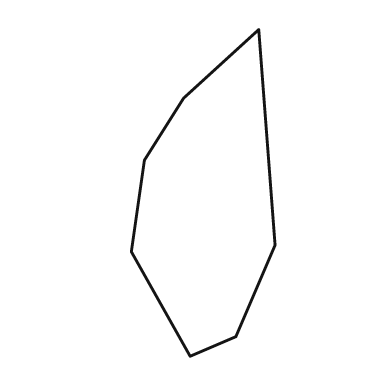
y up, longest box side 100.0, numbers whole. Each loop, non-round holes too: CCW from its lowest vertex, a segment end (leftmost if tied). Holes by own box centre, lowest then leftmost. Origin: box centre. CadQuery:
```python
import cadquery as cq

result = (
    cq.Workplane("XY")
    .moveTo(-4.0, -50.0)
    .lineTo(10.0, -44.0)
    .lineTo(22.0, -16.0)
    .lineTo(17.0, 50.0)
    .lineTo(-6.0, 29.0)
    .lineTo(-18.0, 10.0)
    .lineTo(-22.0, -18.0)
    .close()
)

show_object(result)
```